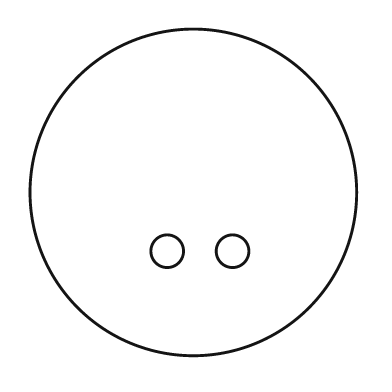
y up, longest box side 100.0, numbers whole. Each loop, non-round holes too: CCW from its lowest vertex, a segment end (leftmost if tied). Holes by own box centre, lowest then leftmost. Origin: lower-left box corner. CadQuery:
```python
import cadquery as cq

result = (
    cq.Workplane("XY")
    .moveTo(50.0, 50.0)
    .circle(50.0)
    .moveTo(42.0, 32.0)
    .circle(5.0)
    .moveTo(62.0, 32.0)
    .circle(5.0)
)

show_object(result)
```